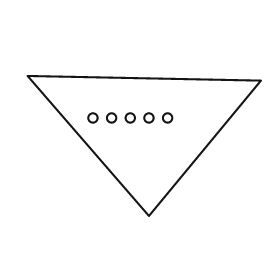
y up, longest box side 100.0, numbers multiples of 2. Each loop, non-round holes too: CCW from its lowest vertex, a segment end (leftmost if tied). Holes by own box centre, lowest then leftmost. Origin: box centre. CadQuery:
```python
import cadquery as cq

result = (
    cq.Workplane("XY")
    .moveTo(2.0, -30.0)
    .lineTo(50.0, 28.0)
    .lineTo(-50.0, 30.0)
    .close()
    .moveTo(-22.0, 12.0)
    .circle(2.0)
    .moveTo(-14.0, 12.0)
    .circle(2.0)
    .moveTo(-6.0, 12.0)
    .circle(2.0)
    .moveTo(2.0, 12.0)
    .circle(2.0)
    .moveTo(10.0, 12.0)
    .circle(2.0)
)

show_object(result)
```